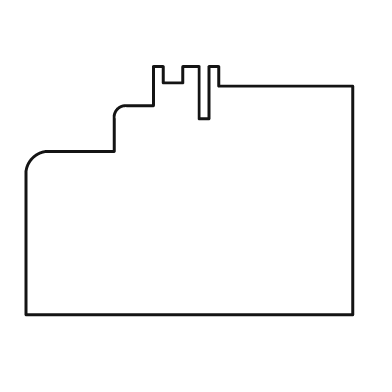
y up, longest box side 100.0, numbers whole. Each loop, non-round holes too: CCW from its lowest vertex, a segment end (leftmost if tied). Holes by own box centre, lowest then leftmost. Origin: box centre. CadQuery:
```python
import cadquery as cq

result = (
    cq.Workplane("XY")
    .moveTo(-50.0, -38.0)
    .lineTo(50.0, -38.0)
    .lineTo(50.0, 32.0)
    .lineTo(9.0, 32.0)
    .lineTo(9.0, 38.0)
    .lineTo(6.0, 38.0)
    .lineTo(6.0, 22.0)
    .lineTo(3.0, 22.0)
    .lineTo(3.0, 38.0)
    .lineTo(-2.0, 38.0)
    .lineTo(-2.0, 33.0)
    .lineTo(-8.0, 33.0)
    .lineTo(-8.0, 38.0)
    .lineTo(-11.0, 38.0)
    .lineTo(-11.0, 26.0)
    .lineTo(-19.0, 26.0)
    .threePointArc((-22.0, 25.0), (-23.0, 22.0))
    .lineTo(-23.0, 12.0)
    .lineTo(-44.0, 12.0)
    .threePointArc((-48.0, 10.0), (-50.0, 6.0))
    .close()
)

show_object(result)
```